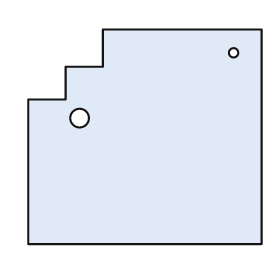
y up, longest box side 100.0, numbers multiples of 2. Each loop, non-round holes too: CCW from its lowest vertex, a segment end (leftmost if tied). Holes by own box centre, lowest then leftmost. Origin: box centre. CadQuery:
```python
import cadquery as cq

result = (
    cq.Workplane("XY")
    .moveTo(-50.0, -46.0)
    .lineTo(50.0, -46.0)
    .lineTo(50.0, 46.0)
    .lineTo(-18.0, 46.0)
    .lineTo(-18.0, 30.0)
    .lineTo(-34.0, 30.0)
    .lineTo(-34.0, 16.0)
    .lineTo(-50.0, 16.0)
    .close()
    .moveTo(-28.0, 8.0)
    .circle(4.0)
    .moveTo(38.0, 36.0)
    .circle(2.0)
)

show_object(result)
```